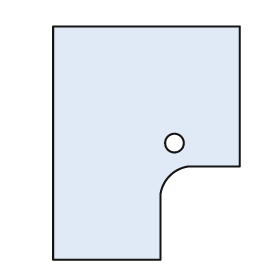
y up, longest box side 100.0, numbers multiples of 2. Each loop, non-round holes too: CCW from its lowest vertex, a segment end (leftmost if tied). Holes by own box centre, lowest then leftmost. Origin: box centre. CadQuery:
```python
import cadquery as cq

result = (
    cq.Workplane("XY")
    .moveTo(-40.0, -50.0)
    .lineTo(6.0, -50.0)
    .lineTo(6.0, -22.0)
    .threePointArc((10.0, -14.0), (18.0, -10.0))
    .lineTo(40.0, -10.0)
    .lineTo(40.0, 50.0)
    .lineTo(-40.0, 50.0)
    .close()
    .moveTo(12.0, 0.0)
    .circle(4.0)
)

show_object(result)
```